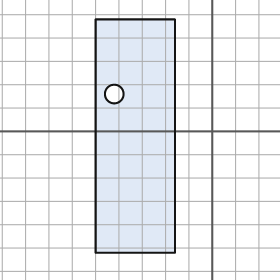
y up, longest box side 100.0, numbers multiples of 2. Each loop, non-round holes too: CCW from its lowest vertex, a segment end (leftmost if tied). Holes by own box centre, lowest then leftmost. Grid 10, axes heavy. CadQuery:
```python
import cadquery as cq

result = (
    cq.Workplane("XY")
    .moveTo(-50.0, -52.0)
    .lineTo(-16.0, -52.0)
    .lineTo(-16.0, 48.0)
    .lineTo(-50.0, 48.0)
    .close()
    .moveTo(-42.0, 16.0)
    .circle(4.0)
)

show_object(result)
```